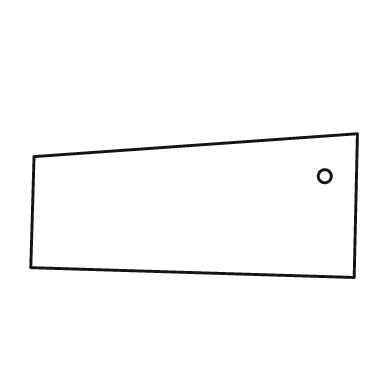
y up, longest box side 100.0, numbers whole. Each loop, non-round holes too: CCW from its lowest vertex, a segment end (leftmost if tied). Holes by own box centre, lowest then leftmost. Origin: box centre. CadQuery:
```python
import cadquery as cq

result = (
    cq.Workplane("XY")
    .moveTo(49.0, -22.0)
    .lineTo(50.0, 22.0)
    .lineTo(-49.0, 15.0)
    .lineTo(-50.0, -19.0)
    .close()
    .moveTo(40.0, 9.0)
    .circle(2.0)
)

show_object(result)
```